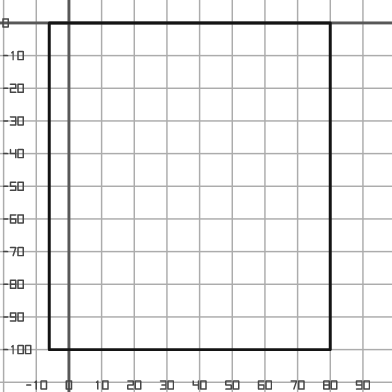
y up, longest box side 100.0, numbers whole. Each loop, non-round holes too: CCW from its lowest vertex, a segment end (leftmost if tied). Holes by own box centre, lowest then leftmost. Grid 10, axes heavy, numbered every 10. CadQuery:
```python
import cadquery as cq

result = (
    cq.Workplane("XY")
    .moveTo(-6.0, -100.0)
    .lineTo(80.0, -100.0)
    .lineTo(80.0, 0.0)
    .lineTo(-6.0, 0.0)
    .close()
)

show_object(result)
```